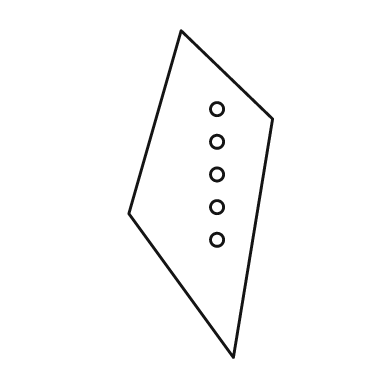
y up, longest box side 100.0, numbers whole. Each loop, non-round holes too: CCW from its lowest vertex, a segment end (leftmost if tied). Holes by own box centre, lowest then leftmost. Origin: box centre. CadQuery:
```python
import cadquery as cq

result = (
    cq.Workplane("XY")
    .moveTo(10.0, -50.0)
    .lineTo(22.0, 23.0)
    .lineTo(-6.0, 50.0)
    .lineTo(-22.0, -6.0)
    .close()
    .moveTo(5.0, -14.0)
    .circle(2.0)
    .moveTo(5.0, -4.0)
    .circle(2.0)
    .moveTo(5.0, 6.0)
    .circle(2.0)
    .moveTo(5.0, 16.0)
    .circle(2.0)
    .moveTo(5.0, 26.0)
    .circle(2.0)
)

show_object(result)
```